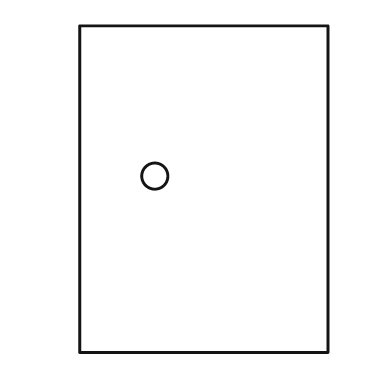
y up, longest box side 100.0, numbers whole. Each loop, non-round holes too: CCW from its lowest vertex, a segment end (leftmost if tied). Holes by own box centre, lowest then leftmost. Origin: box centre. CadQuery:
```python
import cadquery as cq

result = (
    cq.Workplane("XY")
    .moveTo(-38.0, -50.0)
    .lineTo(38.0, -50.0)
    .lineTo(38.0, 50.0)
    .lineTo(-38.0, 50.0)
    .close()
    .moveTo(-15.0, 4.0)
    .circle(4.0)
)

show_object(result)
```